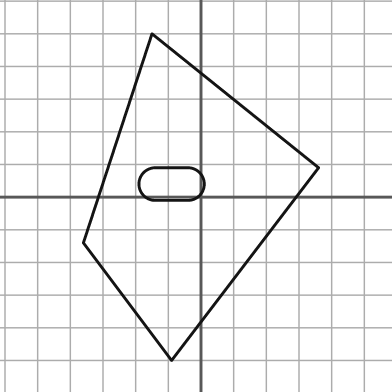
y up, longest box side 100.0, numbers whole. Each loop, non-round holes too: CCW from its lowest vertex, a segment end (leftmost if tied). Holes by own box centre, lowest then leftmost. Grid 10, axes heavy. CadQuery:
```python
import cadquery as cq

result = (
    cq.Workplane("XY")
    .moveTo(-9.0, -50.0)
    .lineTo(36.0, 9.0)
    .lineTo(-15.0, 50.0)
    .lineTo(-36.0, -14.0)
    .close()
    .moveTo(-14.0, -1.0)
    .lineTo(-4.0, -1.0)
    .threePointArc((1.0, 4.0), (-4.0, 9.0))
    .lineTo(-14.0, 9.0)
    .threePointArc((-19.0, 4.0), (-14.0, -1.0))
    .close()
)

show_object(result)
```